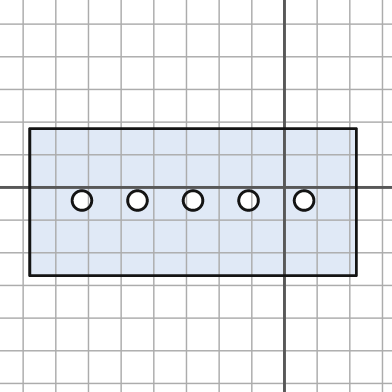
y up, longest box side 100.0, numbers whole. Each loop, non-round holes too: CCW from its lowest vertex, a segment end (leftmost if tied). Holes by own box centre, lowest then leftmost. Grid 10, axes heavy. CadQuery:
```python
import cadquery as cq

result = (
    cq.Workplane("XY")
    .moveTo(-78.0, -27.0)
    .lineTo(22.0, -27.0)
    .lineTo(22.0, 18.0)
    .lineTo(-78.0, 18.0)
    .close()
    .moveTo(-62.0, -4.0)
    .circle(3.0)
    .moveTo(-45.0, -4.0)
    .circle(3.0)
    .moveTo(-28.0, -4.0)
    .circle(3.0)
    .moveTo(-11.0, -4.0)
    .circle(3.0)
    .moveTo(6.0, -4.0)
    .circle(3.0)
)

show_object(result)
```